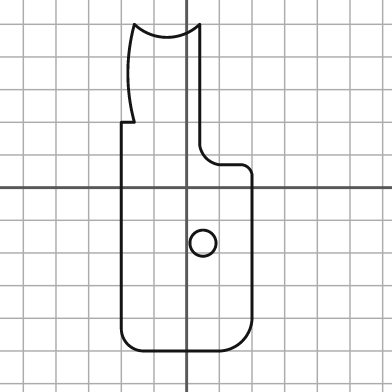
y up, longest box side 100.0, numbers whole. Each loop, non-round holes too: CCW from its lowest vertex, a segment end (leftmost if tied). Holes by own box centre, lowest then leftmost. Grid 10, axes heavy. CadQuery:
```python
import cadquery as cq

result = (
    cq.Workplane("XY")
    .moveTo(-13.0, -50.0)
    .lineTo(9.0, -50.0)
    .threePointArc((17.0, -47.0), (20.0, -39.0))
    .lineTo(20.0, 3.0)
    .threePointArc((19.0, 6.0), (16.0, 7.0))
    .lineTo(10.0, 7.0)
    .threePointArc((6.0, 9.0), (4.0, 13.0))
    .lineTo(4.0, 50.0)
    .threePointArc((-6.0, 46.0), (-16.0, 50.0))
    .threePointArc((-18.0, 35.0), (-16.0, 20.0))
    .lineTo(-20.0, 20.0)
    .lineTo(-20.0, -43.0)
    .threePointArc((-18.0, -48.0), (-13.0, -50.0))
    .close()
    .moveTo(5.0, -17.0)
    .circle(4.0)
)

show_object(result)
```